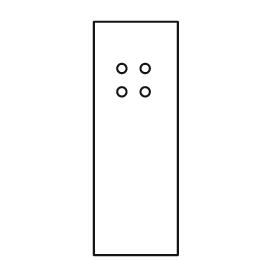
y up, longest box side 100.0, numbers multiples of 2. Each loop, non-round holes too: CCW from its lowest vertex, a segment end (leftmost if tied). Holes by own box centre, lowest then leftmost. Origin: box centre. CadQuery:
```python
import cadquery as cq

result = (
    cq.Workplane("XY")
    .moveTo(-18.0, -50.0)
    .lineTo(18.0, -50.0)
    .lineTo(18.0, 50.0)
    .lineTo(-18.0, 50.0)
    .close()
    .moveTo(-6.0, 20.0)
    .circle(2.0)
    .moveTo(4.0, 20.0)
    .circle(2.0)
    .moveTo(-6.0, 30.0)
    .circle(2.0)
    .moveTo(4.0, 30.0)
    .circle(2.0)
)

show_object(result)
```